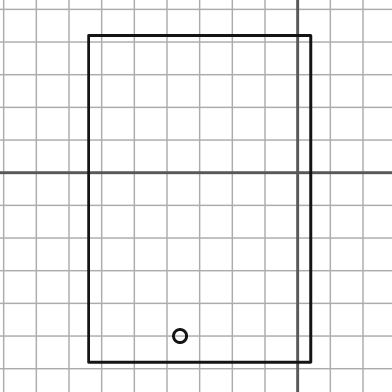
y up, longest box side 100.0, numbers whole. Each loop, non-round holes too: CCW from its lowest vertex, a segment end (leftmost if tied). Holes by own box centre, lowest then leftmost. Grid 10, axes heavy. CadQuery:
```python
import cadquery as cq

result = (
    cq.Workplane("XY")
    .moveTo(-64.0, -58.0)
    .lineTo(4.0, -58.0)
    .lineTo(4.0, 42.0)
    .lineTo(-64.0, 42.0)
    .close()
    .moveTo(-36.0, -50.0)
    .circle(2.0)
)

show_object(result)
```